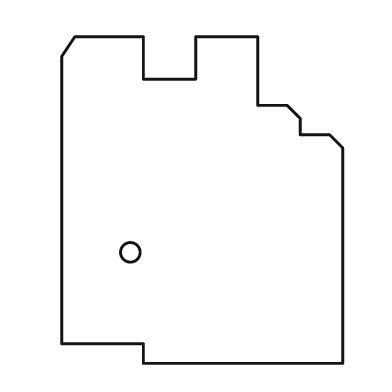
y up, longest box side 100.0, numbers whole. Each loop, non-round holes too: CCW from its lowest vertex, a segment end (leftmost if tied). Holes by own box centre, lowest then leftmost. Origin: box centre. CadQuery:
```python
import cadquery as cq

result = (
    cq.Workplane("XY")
    .moveTo(-18.0, -50.0)
    .lineTo(43.0, -50.0)
    .lineTo(43.0, 16.0)
    .lineTo(39.0, 20.0)
    .lineTo(30.0, 20.0)
    .lineTo(30.0, 25.0)
    .lineTo(26.0, 29.0)
    .lineTo(17.0, 29.0)
    .lineTo(17.0, 50.0)
    .lineTo(-2.0, 50.0)
    .lineTo(-2.0, 37.0)
    .lineTo(-18.0, 37.0)
    .lineTo(-18.0, 50.0)
    .lineTo(-39.0, 50.0)
    .lineTo(-43.0, 44.0)
    .lineTo(-43.0, -44.0)
    .lineTo(-18.0, -44.0)
    .close()
    .moveTo(-22.0, -16.0)
    .circle(3.0)
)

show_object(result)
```